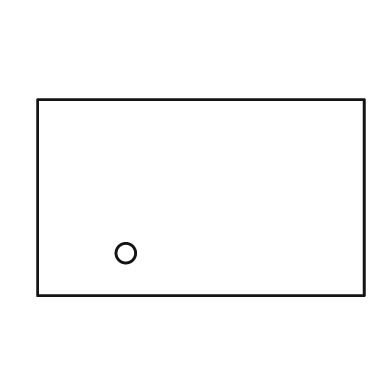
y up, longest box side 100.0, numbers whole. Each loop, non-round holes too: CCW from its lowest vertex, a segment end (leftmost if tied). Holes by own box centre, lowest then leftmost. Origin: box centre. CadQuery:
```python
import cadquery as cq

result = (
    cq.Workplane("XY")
    .moveTo(-50.0, -30.0)
    .lineTo(50.0, -30.0)
    .lineTo(50.0, 30.0)
    .lineTo(-50.0, 30.0)
    .close()
    .moveTo(-23.0, -17.0)
    .circle(3.0)
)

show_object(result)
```